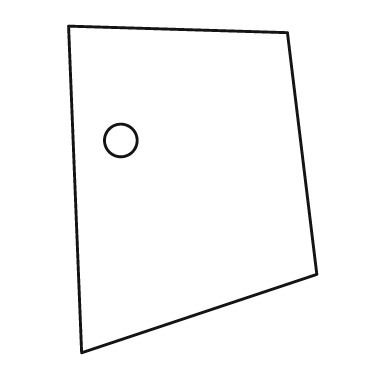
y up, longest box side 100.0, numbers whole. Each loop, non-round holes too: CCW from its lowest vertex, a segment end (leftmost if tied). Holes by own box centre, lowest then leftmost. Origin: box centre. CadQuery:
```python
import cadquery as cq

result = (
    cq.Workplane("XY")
    .moveTo(-34.0, -50.0)
    .lineTo(38.0, -26.0)
    .lineTo(29.0, 48.0)
    .lineTo(-38.0, 50.0)
    .close()
    .moveTo(-22.0, 15.0)
    .circle(5.0)
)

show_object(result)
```